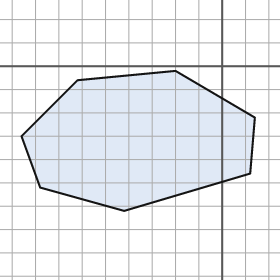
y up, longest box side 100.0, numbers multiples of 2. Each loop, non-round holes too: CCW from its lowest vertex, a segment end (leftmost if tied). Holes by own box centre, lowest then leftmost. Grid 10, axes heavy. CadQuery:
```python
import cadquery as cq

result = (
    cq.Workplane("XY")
    .moveTo(-42.0, -62.0)
    .lineTo(12.0, -46.0)
    .lineTo(14.0, -22.0)
    .lineTo(-20.0, -2.0)
    .lineTo(-62.0, -6.0)
    .lineTo(-86.0, -30.0)
    .lineTo(-78.0, -52.0)
    .close()
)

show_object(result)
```